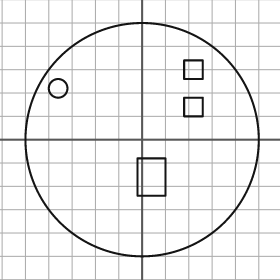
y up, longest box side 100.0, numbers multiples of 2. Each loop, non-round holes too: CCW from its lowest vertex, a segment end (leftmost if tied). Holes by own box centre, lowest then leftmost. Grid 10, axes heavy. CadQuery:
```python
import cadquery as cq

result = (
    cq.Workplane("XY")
    .moveTo(0.0, 0.0)
    .circle(50.0)
    .moveTo(-2.0, -24.0)
    .lineTo(10.0, -24.0)
    .lineTo(10.0, -8.0)
    .lineTo(-2.0, -8.0)
    .close()
    .moveTo(18.0, 10.0)
    .lineTo(26.0, 10.0)
    .lineTo(26.0, 18.0)
    .lineTo(18.0, 18.0)
    .close()
    .moveTo(-36.0, 22.0)
    .circle(4.0)
    .moveTo(18.0, 26.0)
    .lineTo(26.0, 26.0)
    .lineTo(26.0, 34.0)
    .lineTo(18.0, 34.0)
    .close()
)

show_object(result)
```